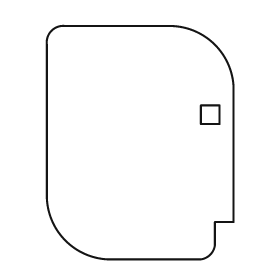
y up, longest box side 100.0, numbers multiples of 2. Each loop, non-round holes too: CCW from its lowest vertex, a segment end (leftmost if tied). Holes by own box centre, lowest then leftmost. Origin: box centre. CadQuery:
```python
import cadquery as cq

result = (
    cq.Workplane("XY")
    .moveTo(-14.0, -50.0)
    .lineTo(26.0, -50.0)
    .threePointArc((30.0, -48.0), (32.0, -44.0))
    .lineTo(32.0, -34.0)
    .lineTo(40.0, -34.0)
    .lineTo(40.0, 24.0)
    .threePointArc((32.0, 42.0), (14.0, 50.0))
    .lineTo(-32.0, 50.0)
    .threePointArc((-38.0, 48.0), (-40.0, 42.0))
    .lineTo(-40.0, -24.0)
    .threePointArc((-32.0, -42.0), (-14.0, -50.0))
    .close()
    .moveTo(26.0, 8.0)
    .lineTo(34.0, 8.0)
    .lineTo(34.0, 16.0)
    .lineTo(26.0, 16.0)
    .close()
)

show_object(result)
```